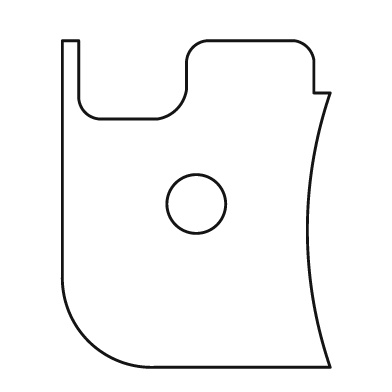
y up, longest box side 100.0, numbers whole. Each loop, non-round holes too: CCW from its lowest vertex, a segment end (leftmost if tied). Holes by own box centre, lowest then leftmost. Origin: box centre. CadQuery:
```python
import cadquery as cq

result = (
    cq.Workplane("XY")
    .moveTo(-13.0, -50.0)
    .lineTo(41.0, -50.0)
    .threePointArc((34.0, -8.0), (41.0, 34.0))
    .lineTo(36.0, 34.0)
    .lineTo(36.0, 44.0)
    .threePointArc((34.0, 48.0), (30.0, 50.0))
    .lineTo(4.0, 50.0)
    .threePointArc((-1.0, 48.0), (-3.0, 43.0))
    .lineTo(-3.0, 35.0)
    .threePointArc((-6.0, 29.0), (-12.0, 26.0))
    .lineTo(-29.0, 26.0)
    .threePointArc((-34.0, 28.0), (-36.0, 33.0))
    .lineTo(-36.0, 50.0)
    .lineTo(-41.0, 50.0)
    .lineTo(-41.0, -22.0)
    .threePointArc((-33.0, -42.0), (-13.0, -50.0))
    .close()
    .moveTo(0.0, 0.0)
    .circle(9.0)
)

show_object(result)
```